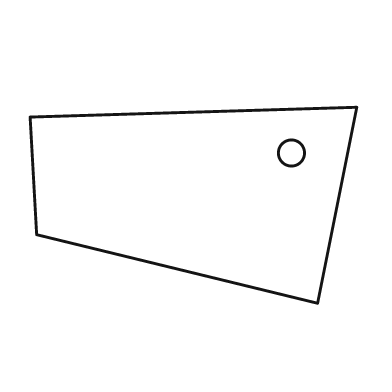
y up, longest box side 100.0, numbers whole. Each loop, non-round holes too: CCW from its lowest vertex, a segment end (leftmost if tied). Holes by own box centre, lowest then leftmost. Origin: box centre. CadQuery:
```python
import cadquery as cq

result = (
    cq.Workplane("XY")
    .moveTo(38.0, -30.0)
    .lineTo(50.0, 30.0)
    .lineTo(-50.0, 27.0)
    .lineTo(-48.0, -9.0)
    .close()
    .moveTo(30.0, 16.0)
    .circle(4.0)
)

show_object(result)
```